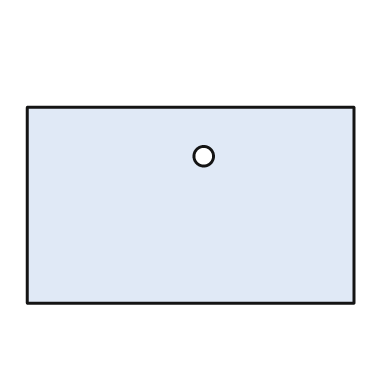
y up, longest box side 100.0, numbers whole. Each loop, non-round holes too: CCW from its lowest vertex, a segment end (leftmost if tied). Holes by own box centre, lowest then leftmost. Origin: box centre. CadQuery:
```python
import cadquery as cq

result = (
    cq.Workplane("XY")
    .moveTo(-50.0, -30.0)
    .lineTo(50.0, -30.0)
    .lineTo(50.0, 30.0)
    .lineTo(-50.0, 30.0)
    .close()
    .moveTo(4.0, 15.0)
    .circle(3.0)
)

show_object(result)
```